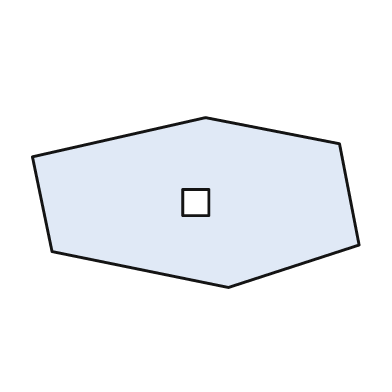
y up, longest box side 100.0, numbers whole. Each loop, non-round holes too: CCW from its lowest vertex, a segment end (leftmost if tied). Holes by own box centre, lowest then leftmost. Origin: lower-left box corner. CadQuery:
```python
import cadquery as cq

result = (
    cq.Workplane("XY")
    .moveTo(60.0, 0.0)
    .lineTo(100.0, 13.0)
    .lineTo(94.0, 44.0)
    .lineTo(53.0, 52.0)
    .lineTo(0.0, 40.0)
    .lineTo(6.0, 11.0)
    .close()
    .moveTo(46.0, 22.0)
    .lineTo(54.0, 22.0)
    .lineTo(54.0, 30.0)
    .lineTo(46.0, 30.0)
    .close()
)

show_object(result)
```